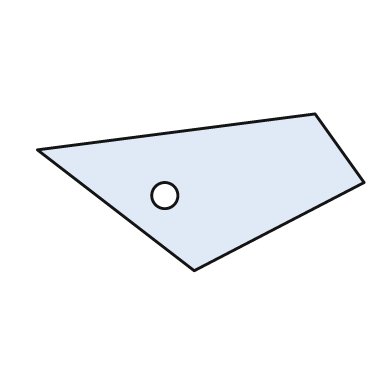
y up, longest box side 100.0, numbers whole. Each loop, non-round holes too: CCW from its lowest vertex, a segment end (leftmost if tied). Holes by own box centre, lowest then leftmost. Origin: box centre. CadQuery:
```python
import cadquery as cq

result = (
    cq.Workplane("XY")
    .moveTo(-2.0, -24.0)
    .lineTo(50.0, 3.0)
    .lineTo(35.0, 24.0)
    .lineTo(-50.0, 13.0)
    .close()
    .moveTo(-11.0, -1.0)
    .circle(4.0)
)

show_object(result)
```